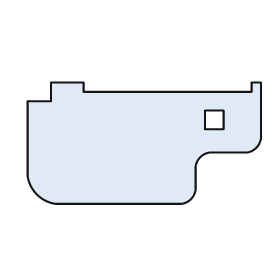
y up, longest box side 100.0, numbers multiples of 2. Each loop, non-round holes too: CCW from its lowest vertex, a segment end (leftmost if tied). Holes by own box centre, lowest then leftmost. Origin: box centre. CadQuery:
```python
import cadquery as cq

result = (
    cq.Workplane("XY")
    .moveTo(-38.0, -26.0)
    .lineTo(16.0, -26.0)
    .threePointArc((20.0, -24.0), (22.0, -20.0))
    .lineTo(22.0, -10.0)
    .threePointArc((24.0, -6.0), (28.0, -4.0))
    .lineTo(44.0, -4.0)
    .threePointArc((48.0, -2.0), (50.0, 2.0))
    .lineTo(50.0, 26.0)
    .lineTo(46.0, 26.0)
    .lineTo(46.0, 22.0)
    .lineTo(-26.0, 22.0)
    .lineTo(-26.0, 26.0)
    .lineTo(-40.0, 26.0)
    .lineTo(-40.0, 18.0)
    .lineTo(-50.0, 18.0)
    .lineTo(-50.0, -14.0)
    .threePointArc((-46.0, -22.0), (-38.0, -26.0))
    .close()
    .moveTo(26.0, 6.0)
    .lineTo(34.0, 6.0)
    .lineTo(34.0, 14.0)
    .lineTo(26.0, 14.0)
    .close()
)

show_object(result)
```